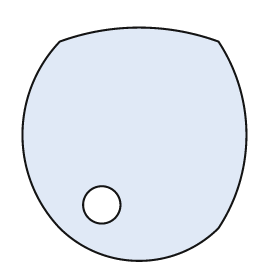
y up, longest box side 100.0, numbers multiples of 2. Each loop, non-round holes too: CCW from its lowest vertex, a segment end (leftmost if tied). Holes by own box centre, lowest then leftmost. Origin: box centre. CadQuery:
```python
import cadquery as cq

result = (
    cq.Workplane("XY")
    .moveTo(-32.0, -36.0)
    .threePointArc((2.0, -50.0), (36.0, -36.0))
    .threePointArc((48.0, 4.0), (36.0, 44.0))
    .threePointArc((2.0, 50.0), (-32.0, 44.0))
    .threePointArc((-48.0, 4.0), (-32.0, -36.0))
    .close()
    .moveTo(-14.0, -26.0)
    .circle(8.0)
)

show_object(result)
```